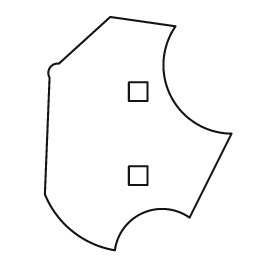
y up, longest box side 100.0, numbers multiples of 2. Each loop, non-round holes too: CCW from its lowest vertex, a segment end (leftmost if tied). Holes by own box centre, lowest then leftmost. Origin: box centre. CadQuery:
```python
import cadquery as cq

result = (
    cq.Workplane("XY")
    .moveTo(-10.0, -50.0)
    .threePointArc((2.0, -34.0), (22.0, -36.0))
    .lineTo(40.0, 0.0)
    .threePointArc((14.0, 16.0), (16.0, 46.0))
    .lineTo(-12.0, 50.0)
    .lineTo(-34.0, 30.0)
    .threePointArc((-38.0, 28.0), (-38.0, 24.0))
    .lineTo(-40.0, -26.0)
    .threePointArc((-28.0, -42.0), (-10.0, -50.0))
    .close()
    .moveTo(-4.0, -22.0)
    .lineTo(4.0, -22.0)
    .lineTo(4.0, -14.0)
    .lineTo(-4.0, -14.0)
    .close()
    .moveTo(-4.0, 14.0)
    .lineTo(4.0, 14.0)
    .lineTo(4.0, 22.0)
    .lineTo(-4.0, 22.0)
    .close()
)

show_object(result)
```